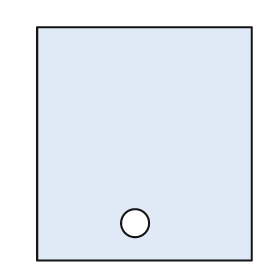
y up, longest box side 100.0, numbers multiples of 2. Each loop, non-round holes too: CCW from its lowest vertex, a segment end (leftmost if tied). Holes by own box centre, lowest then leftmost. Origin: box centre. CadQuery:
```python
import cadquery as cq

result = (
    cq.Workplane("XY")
    .moveTo(-46.0, -50.0)
    .lineTo(46.0, -50.0)
    .lineTo(46.0, 50.0)
    .lineTo(-46.0, 50.0)
    .close()
    .moveTo(-4.0, -34.0)
    .circle(6.0)
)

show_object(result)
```